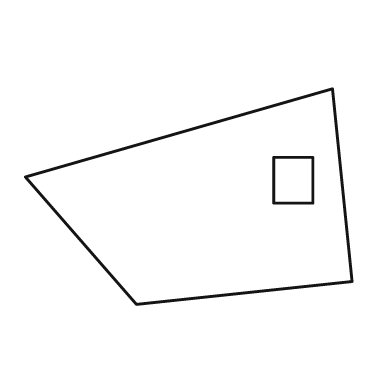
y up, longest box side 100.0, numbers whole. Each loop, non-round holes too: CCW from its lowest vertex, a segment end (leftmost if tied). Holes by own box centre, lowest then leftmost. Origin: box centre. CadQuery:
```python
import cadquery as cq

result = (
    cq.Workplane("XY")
    .moveTo(-16.0, -33.0)
    .lineTo(50.0, -26.0)
    .lineTo(44.0, 33.0)
    .lineTo(-50.0, 6.0)
    .close()
    .moveTo(26.0, -2.0)
    .lineTo(38.0, -2.0)
    .lineTo(38.0, 12.0)
    .lineTo(26.0, 12.0)
    .close()
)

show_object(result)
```